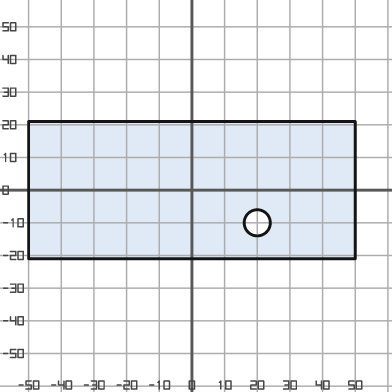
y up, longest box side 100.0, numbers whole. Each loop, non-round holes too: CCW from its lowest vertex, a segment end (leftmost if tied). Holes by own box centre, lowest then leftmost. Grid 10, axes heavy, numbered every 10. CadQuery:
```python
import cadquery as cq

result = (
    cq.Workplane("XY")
    .moveTo(-50.0, -21.0)
    .lineTo(50.0, -21.0)
    .lineTo(50.0, 21.0)
    .lineTo(-50.0, 21.0)
    .close()
    .moveTo(20.0, -10.0)
    .circle(4.0)
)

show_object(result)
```